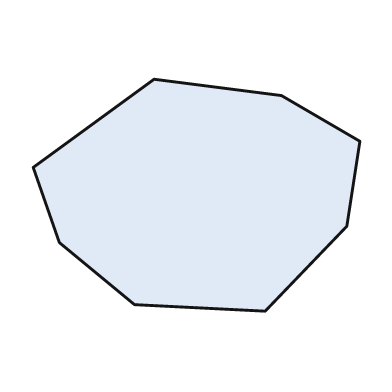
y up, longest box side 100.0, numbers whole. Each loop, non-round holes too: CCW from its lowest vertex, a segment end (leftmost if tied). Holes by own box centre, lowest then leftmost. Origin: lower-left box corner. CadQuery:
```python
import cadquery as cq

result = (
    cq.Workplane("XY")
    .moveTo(71.0, 0.0)
    .lineTo(96.0, 26.0)
    .lineTo(100.0, 52.0)
    .lineTo(76.0, 66.0)
    .lineTo(37.0, 71.0)
    .lineTo(0.0, 44.0)
    .lineTo(8.0, 21.0)
    .lineTo(31.0, 2.0)
    .close()
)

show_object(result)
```